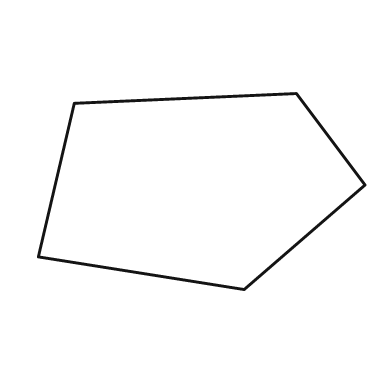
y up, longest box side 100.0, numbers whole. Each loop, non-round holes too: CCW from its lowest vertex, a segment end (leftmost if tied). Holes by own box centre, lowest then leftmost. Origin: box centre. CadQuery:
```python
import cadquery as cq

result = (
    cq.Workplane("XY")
    .moveTo(13.0, -30.0)
    .lineTo(50.0, 2.0)
    .lineTo(29.0, 30.0)
    .lineTo(-39.0, 27.0)
    .lineTo(-50.0, -20.0)
    .close()
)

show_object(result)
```